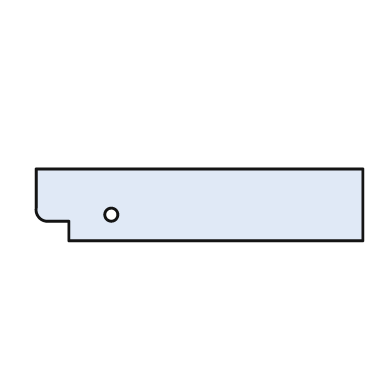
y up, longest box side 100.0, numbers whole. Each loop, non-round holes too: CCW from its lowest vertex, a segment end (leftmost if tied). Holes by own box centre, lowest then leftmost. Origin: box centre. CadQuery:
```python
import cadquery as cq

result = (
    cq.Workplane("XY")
    .moveTo(-40.0, -11.0)
    .lineTo(50.0, -11.0)
    .lineTo(50.0, 11.0)
    .lineTo(-50.0, 11.0)
    .lineTo(-50.0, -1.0)
    .threePointArc((-49.0, -4.0), (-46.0, -5.0))
    .lineTo(-40.0, -5.0)
    .close()
    .moveTo(-27.0, -3.0)
    .circle(2.0)
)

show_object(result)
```